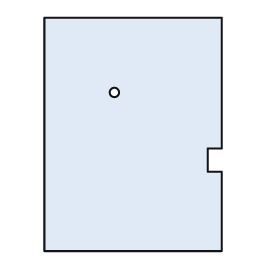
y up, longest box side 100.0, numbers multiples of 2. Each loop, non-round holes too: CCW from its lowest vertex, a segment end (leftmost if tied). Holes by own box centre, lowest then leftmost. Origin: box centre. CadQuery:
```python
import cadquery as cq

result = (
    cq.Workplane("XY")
    .moveTo(-38.0, -50.0)
    .lineTo(38.0, -50.0)
    .lineTo(38.0, -16.0)
    .lineTo(32.0, -16.0)
    .lineTo(32.0, -6.0)
    .lineTo(38.0, -6.0)
    .lineTo(38.0, 50.0)
    .lineTo(-38.0, 50.0)
    .close()
    .moveTo(-8.0, 18.0)
    .circle(2.0)
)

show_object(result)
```